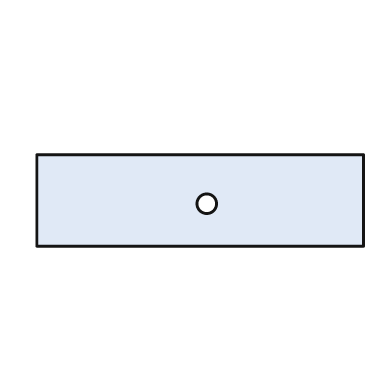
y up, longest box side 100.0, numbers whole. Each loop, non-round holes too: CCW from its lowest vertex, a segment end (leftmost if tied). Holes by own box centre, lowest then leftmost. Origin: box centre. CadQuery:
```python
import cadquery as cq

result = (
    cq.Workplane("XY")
    .moveTo(-50.0, -14.0)
    .lineTo(50.0, -14.0)
    .lineTo(50.0, 14.0)
    .lineTo(-50.0, 14.0)
    .close()
    .moveTo(2.0, -1.0)
    .circle(3.0)
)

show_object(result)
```